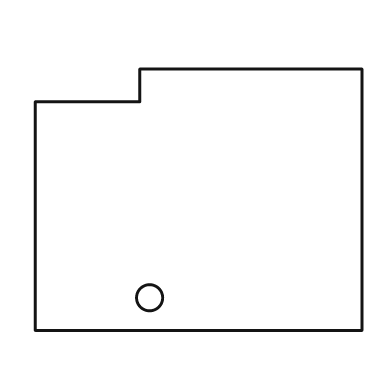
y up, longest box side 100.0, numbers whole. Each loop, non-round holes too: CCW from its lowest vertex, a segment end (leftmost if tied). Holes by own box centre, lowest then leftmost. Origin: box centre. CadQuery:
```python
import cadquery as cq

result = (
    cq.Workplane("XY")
    .moveTo(-50.0, -40.0)
    .lineTo(50.0, -40.0)
    .lineTo(50.0, 40.0)
    .lineTo(-18.0, 40.0)
    .lineTo(-18.0, 30.0)
    .lineTo(-50.0, 30.0)
    .close()
    .moveTo(-15.0, -30.0)
    .circle(4.0)
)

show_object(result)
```